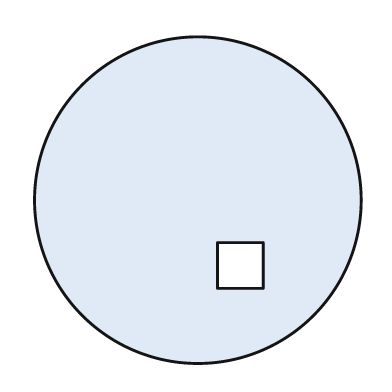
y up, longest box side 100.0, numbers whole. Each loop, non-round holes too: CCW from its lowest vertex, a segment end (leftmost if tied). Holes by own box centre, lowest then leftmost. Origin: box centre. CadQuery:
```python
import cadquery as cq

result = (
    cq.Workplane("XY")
    .moveTo(0.0, 0.0)
    .circle(50.0)
    .moveTo(6.0, -27.0)
    .lineTo(20.0, -27.0)
    .lineTo(20.0, -13.0)
    .lineTo(6.0, -13.0)
    .close()
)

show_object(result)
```